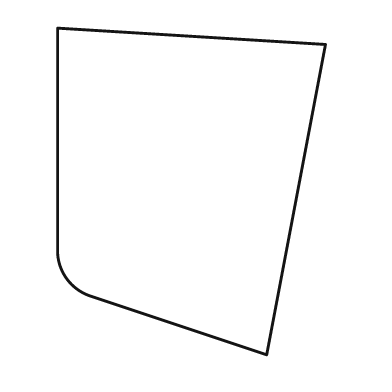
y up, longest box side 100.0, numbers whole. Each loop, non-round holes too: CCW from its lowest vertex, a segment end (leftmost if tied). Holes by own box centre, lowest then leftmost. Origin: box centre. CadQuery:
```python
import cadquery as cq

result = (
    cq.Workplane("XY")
    .moveTo(23.0, -50.0)
    .lineTo(41.0, 45.0)
    .lineTo(-41.0, 50.0)
    .lineTo(-41.0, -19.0)
    .threePointArc((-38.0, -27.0), (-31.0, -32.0))
    .close()
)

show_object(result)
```